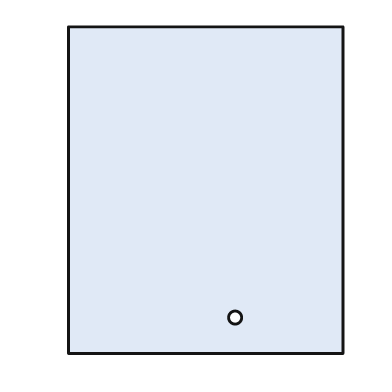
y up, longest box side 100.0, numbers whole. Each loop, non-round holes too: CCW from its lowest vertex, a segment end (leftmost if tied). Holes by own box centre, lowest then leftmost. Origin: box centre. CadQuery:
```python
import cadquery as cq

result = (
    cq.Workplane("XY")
    .moveTo(-42.0, -50.0)
    .lineTo(42.0, -50.0)
    .lineTo(42.0, 50.0)
    .lineTo(-42.0, 50.0)
    .close()
    .moveTo(9.0, -39.0)
    .circle(2.0)
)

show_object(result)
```